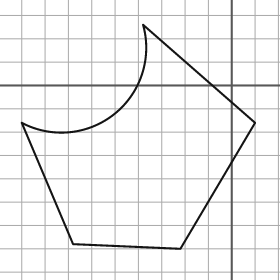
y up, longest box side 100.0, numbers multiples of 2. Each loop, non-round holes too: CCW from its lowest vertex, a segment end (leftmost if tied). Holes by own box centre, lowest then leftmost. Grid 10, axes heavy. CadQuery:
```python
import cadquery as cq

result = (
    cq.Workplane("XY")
    .moveTo(-22.0, -70.0)
    .lineTo(10.0, -16.0)
    .lineTo(-38.0, 26.0)
    .threePointArc((-50.0, -12.0), (-90.0, -16.0))
    .lineTo(-68.0, -68.0)
    .close()
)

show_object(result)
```